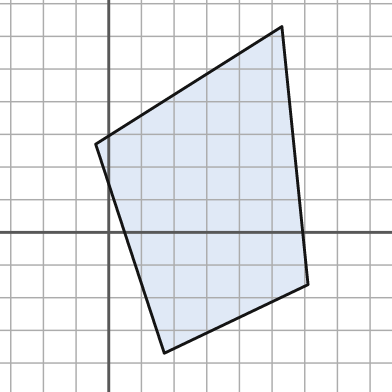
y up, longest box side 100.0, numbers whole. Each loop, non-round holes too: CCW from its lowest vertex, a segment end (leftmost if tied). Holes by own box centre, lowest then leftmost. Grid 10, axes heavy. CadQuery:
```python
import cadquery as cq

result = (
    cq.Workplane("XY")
    .moveTo(17.0, -37.0)
    .lineTo(61.0, -16.0)
    .lineTo(53.0, 63.0)
    .lineTo(-4.0, 27.0)
    .close()
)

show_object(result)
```